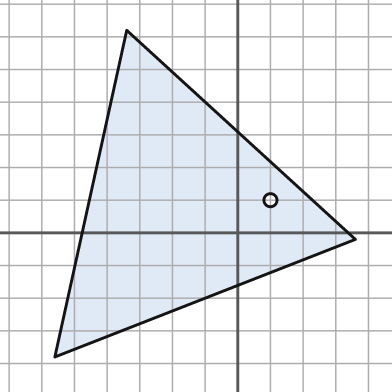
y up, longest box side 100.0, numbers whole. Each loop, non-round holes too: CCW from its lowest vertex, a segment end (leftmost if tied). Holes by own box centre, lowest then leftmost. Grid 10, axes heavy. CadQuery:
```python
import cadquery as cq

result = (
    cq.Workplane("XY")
    .moveTo(-56.0, -38.0)
    .lineTo(36.0, -2.0)
    .lineTo(-34.0, 62.0)
    .close()
    .moveTo(10.0, 10.0)
    .circle(2.0)
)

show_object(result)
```